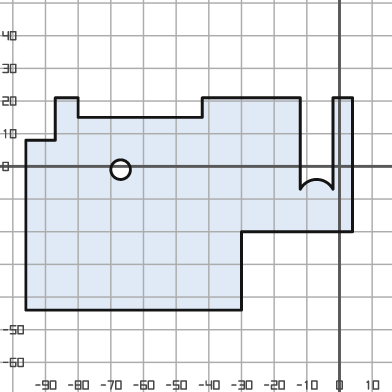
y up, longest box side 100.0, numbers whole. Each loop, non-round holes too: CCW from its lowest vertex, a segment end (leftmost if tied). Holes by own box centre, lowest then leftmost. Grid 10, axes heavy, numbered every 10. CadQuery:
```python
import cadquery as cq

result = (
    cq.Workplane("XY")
    .moveTo(-96.0, -44.0)
    .lineTo(-30.0, -44.0)
    .lineTo(-30.0, -20.0)
    .lineTo(4.0, -20.0)
    .lineTo(4.0, 21.0)
    .lineTo(-2.0, 21.0)
    .lineTo(-2.0, -7.0)
    .threePointArc((-7.0, -4.0), (-12.0, -7.0))
    .lineTo(-12.0, 21.0)
    .lineTo(-42.0, 21.0)
    .lineTo(-42.0, 15.0)
    .lineTo(-80.0, 15.0)
    .lineTo(-80.0, 21.0)
    .lineTo(-87.0, 21.0)
    .lineTo(-87.0, 8.0)
    .lineTo(-96.0, 8.0)
    .close()
    .moveTo(-67.0, -1.0)
    .circle(3.0)
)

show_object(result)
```